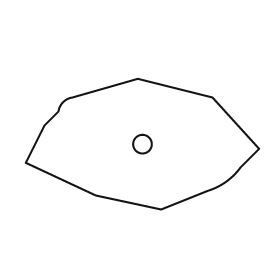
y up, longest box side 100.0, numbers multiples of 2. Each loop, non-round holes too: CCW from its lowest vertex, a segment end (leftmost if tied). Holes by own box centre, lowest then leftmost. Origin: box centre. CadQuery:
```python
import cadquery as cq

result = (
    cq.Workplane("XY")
    .moveTo(8.0, -28.0)
    .lineTo(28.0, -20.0)
    .threePointArc((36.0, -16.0), (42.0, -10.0))
    .lineTo(50.0, -2.0)
    .lineTo(30.0, 20.0)
    .lineTo(-2.0, 28.0)
    .lineTo(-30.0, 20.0)
    .threePointArc((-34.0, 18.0), (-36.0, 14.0))
    .lineTo(-42.0, 8.0)
    .lineTo(-50.0, -8.0)
    .lineTo(-20.0, -22.0)
    .close()
    .moveTo(0.0, 0.0)
    .circle(4.0)
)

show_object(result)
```